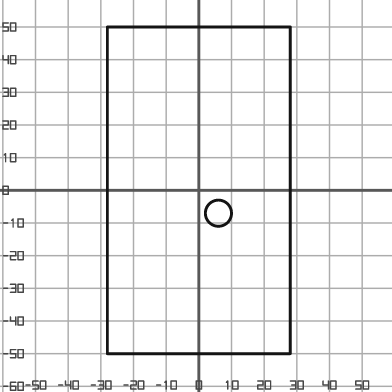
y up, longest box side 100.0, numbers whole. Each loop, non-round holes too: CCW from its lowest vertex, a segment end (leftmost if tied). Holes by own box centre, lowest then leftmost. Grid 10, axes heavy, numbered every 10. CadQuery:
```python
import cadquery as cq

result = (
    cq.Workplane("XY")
    .moveTo(-28.0, -50.0)
    .lineTo(28.0, -50.0)
    .lineTo(28.0, 50.0)
    .lineTo(-28.0, 50.0)
    .close()
    .moveTo(6.0, -7.0)
    .circle(4.0)
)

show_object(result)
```